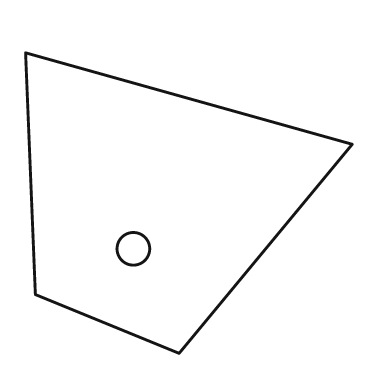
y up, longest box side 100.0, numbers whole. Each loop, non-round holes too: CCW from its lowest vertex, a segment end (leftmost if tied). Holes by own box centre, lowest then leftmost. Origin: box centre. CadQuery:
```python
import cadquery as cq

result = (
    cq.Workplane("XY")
    .moveTo(-3.0, -46.0)
    .lineTo(50.0, 18.0)
    .lineTo(-50.0, 46.0)
    .lineTo(-47.0, -28.0)
    .close()
    .moveTo(-17.0, -14.0)
    .circle(5.0)
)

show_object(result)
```